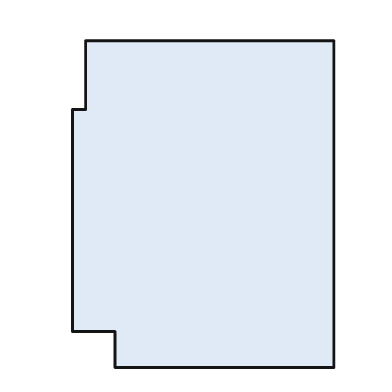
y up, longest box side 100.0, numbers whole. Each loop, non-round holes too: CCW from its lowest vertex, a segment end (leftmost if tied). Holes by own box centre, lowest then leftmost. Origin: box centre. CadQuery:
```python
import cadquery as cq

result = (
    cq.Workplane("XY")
    .moveTo(-27.0, -50.0)
    .lineTo(40.0, -50.0)
    .lineTo(40.0, 50.0)
    .lineTo(-36.0, 50.0)
    .lineTo(-36.0, 29.0)
    .lineTo(-40.0, 29.0)
    .lineTo(-40.0, -39.0)
    .lineTo(-27.0, -39.0)
    .close()
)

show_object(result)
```